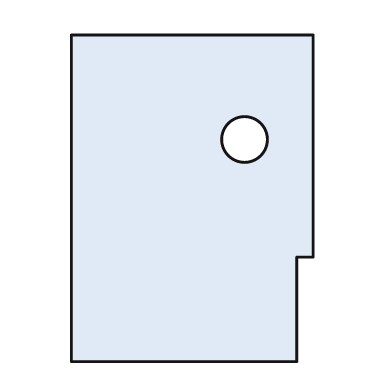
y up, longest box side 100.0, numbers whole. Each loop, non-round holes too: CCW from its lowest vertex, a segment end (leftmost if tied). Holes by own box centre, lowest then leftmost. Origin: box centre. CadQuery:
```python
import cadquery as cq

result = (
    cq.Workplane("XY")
    .moveTo(-37.0, -50.0)
    .lineTo(32.0, -50.0)
    .lineTo(32.0, -18.0)
    .lineTo(37.0, -18.0)
    .lineTo(37.0, 50.0)
    .lineTo(-37.0, 50.0)
    .close()
    .moveTo(16.0, 18.0)
    .circle(7.0)
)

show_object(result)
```